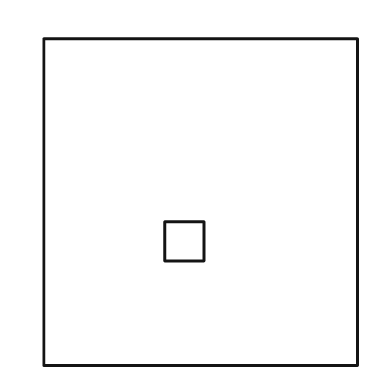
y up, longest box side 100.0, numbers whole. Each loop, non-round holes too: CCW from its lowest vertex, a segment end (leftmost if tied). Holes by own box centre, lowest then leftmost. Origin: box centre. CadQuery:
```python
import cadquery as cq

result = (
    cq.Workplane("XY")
    .moveTo(-48.0, -50.0)
    .lineTo(48.0, -50.0)
    .lineTo(48.0, 50.0)
    .lineTo(-48.0, 50.0)
    .close()
    .moveTo(-11.0, -18.0)
    .lineTo(1.0, -18.0)
    .lineTo(1.0, -6.0)
    .lineTo(-11.0, -6.0)
    .close()
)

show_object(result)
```